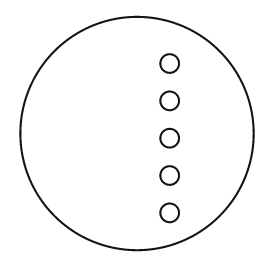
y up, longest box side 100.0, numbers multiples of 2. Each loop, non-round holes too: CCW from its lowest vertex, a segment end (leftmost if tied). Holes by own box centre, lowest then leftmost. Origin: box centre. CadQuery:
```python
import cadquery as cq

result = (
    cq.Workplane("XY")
    .moveTo(0.0, 0.0)
    .circle(50.0)
    .moveTo(14.0, -34.0)
    .circle(4.0)
    .moveTo(14.0, -18.0)
    .circle(4.0)
    .moveTo(14.0, -2.0)
    .circle(4.0)
    .moveTo(14.0, 14.0)
    .circle(4.0)
    .moveTo(14.0, 30.0)
    .circle(4.0)
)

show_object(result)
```